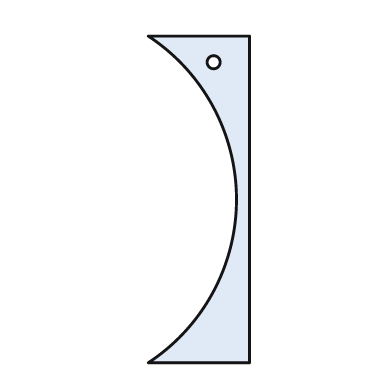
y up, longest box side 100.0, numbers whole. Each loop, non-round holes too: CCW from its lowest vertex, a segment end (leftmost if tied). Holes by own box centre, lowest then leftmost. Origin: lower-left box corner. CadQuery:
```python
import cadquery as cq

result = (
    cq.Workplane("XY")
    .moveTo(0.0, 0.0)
    .lineTo(31.0, 0.0)
    .lineTo(31.0, 100.0)
    .lineTo(0.0, 100.0)
    .threePointArc((27.0, 50.0), (0.0, 0.0))
    .close()
    .moveTo(20.0, 92.0)
    .circle(2.0)
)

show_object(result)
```